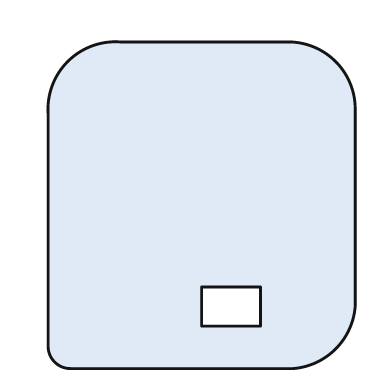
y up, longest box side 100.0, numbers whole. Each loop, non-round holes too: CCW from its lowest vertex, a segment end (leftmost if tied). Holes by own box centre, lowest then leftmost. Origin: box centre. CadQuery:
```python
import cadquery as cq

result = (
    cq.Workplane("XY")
    .moveTo(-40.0, -50.0)
    .lineTo(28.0, -50.0)
    .threePointArc((41.0, -44.0), (47.0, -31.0))
    .lineTo(47.0, 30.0)
    .threePointArc((41.0, 44.0), (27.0, 50.0))
    .lineTo(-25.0, 50.0)
    .threePointArc((-41.0, 44.0), (-47.0, 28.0))
    .lineTo(-47.0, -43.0)
    .threePointArc((-45.0, -48.0), (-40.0, -50.0))
    .close()
    .moveTo(0.0, -37.0)
    .lineTo(18.0, -37.0)
    .lineTo(18.0, -25.0)
    .lineTo(0.0, -25.0)
    .close()
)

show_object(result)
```